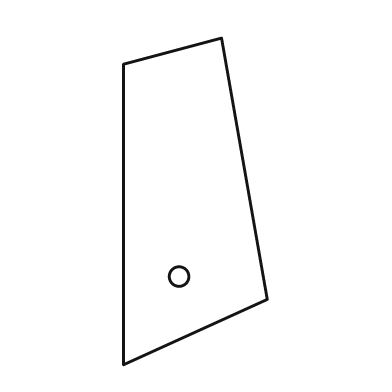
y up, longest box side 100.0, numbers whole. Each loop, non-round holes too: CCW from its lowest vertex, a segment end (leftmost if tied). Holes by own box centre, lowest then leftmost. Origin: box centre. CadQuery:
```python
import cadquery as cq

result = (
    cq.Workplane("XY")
    .moveTo(-22.0, -50.0)
    .lineTo(22.0, -30.0)
    .lineTo(8.0, 50.0)
    .lineTo(-22.0, 42.0)
    .close()
    .moveTo(-5.0, -23.0)
    .circle(3.0)
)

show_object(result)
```